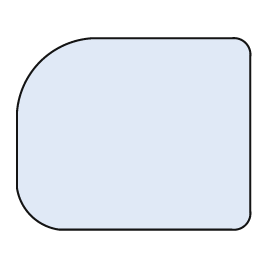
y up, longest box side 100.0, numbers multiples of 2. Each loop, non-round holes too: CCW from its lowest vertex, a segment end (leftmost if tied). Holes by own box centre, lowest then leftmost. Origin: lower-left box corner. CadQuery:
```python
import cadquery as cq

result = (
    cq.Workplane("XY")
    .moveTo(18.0, 0.0)
    .lineTo(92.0, 0.0)
    .threePointArc((98.0, 2.0), (100.0, 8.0))
    .lineTo(100.0, 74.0)
    .threePointArc((98.0, 80.0), (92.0, 82.0))
    .lineTo(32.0, 82.0)
    .threePointArc((10.0, 72.0), (0.0, 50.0))
    .lineTo(0.0, 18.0)
    .threePointArc((6.0, 6.0), (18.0, 0.0))
    .close()
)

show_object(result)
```